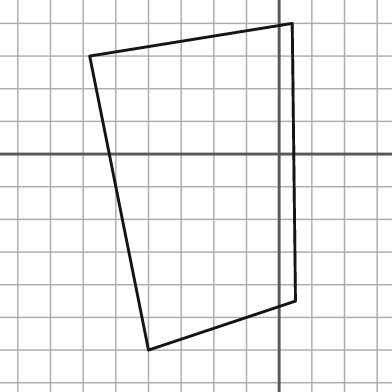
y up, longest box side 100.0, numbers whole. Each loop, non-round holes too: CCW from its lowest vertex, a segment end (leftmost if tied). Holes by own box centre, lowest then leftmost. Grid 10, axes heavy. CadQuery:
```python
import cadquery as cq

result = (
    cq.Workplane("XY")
    .moveTo(-40.0, -60.0)
    .lineTo(5.0, -45.0)
    .lineTo(4.0, 40.0)
    .lineTo(-58.0, 30.0)
    .close()
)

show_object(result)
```